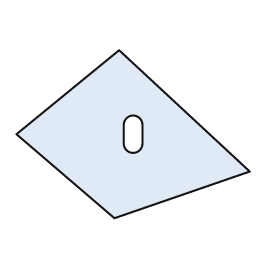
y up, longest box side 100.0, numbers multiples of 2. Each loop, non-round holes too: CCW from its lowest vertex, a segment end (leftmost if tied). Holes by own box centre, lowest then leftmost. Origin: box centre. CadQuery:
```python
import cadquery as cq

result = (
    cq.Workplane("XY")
    .moveTo(-8.0, -36.0)
    .lineTo(50.0, -16.0)
    .lineTo(-6.0, 36.0)
    .lineTo(-50.0, 0.0)
    .close()
    .moveTo(-4.0, -4.0)
    .threePointArc((0.0, -8.0), (4.0, -4.0))
    .lineTo(4.0, 4.0)
    .threePointArc((0.0, 8.0), (-4.0, 4.0))
    .close()
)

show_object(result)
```